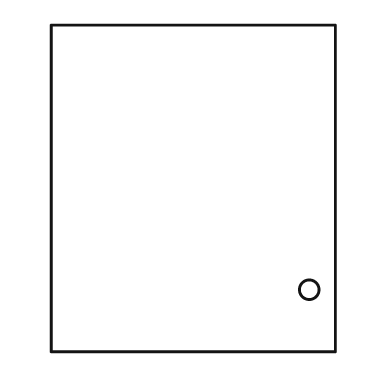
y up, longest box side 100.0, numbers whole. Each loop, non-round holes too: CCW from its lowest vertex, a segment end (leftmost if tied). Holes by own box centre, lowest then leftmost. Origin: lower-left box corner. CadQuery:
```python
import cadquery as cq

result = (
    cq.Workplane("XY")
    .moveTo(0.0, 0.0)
    .lineTo(87.0, 0.0)
    .lineTo(87.0, 100.0)
    .lineTo(0.0, 100.0)
    .close()
    .moveTo(79.0, 19.0)
    .circle(3.0)
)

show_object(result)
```